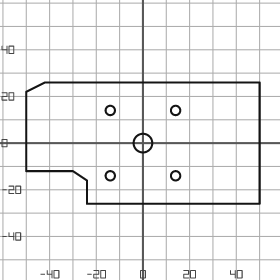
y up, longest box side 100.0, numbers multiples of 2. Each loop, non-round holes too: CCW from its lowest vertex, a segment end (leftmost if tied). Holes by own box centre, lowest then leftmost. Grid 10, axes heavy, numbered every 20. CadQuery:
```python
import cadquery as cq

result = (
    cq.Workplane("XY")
    .moveTo(-24.0, -26.0)
    .lineTo(50.0, -26.0)
    .lineTo(50.0, 26.0)
    .lineTo(-42.0, 26.0)
    .lineTo(-50.0, 22.0)
    .lineTo(-50.0, -12.0)
    .lineTo(-30.0, -12.0)
    .lineTo(-24.0, -16.0)
    .close()
    .moveTo(-14.0, -14.0)
    .circle(2.0)
    .moveTo(14.0, -14.0)
    .circle(2.0)
    .moveTo(0.0, 0.0)
    .circle(4.0)
    .moveTo(-14.0, 14.0)
    .circle(2.0)
    .moveTo(14.0, 14.0)
    .circle(2.0)
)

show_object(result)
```